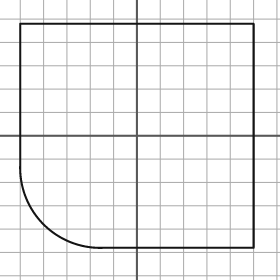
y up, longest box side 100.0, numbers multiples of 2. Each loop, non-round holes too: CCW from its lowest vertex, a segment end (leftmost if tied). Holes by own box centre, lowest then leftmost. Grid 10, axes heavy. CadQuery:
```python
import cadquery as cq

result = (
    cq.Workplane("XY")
    .moveTo(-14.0, -48.0)
    .lineTo(50.0, -48.0)
    .lineTo(50.0, 48.0)
    .lineTo(-50.0, 48.0)
    .lineTo(-50.0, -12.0)
    .threePointArc((-40.0, -38.0), (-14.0, -48.0))
    .close()
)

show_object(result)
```